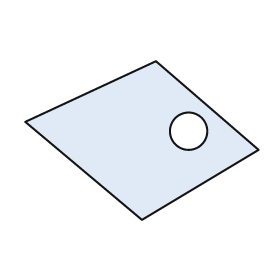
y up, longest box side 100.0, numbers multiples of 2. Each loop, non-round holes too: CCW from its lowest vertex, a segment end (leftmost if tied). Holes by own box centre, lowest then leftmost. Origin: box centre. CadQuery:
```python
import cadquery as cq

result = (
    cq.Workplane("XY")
    .moveTo(0.0, -34.0)
    .lineTo(50.0, -4.0)
    .lineTo(6.0, 34.0)
    .lineTo(-50.0, 8.0)
    .close()
    .moveTo(20.0, 4.0)
    .circle(8.0)
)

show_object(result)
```